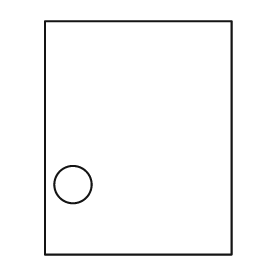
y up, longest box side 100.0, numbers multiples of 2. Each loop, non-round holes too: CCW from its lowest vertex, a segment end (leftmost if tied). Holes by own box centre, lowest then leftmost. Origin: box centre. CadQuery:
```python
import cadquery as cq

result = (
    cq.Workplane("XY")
    .moveTo(-40.0, -50.0)
    .lineTo(40.0, -50.0)
    .lineTo(40.0, 50.0)
    .lineTo(-40.0, 50.0)
    .close()
    .moveTo(-28.0, -20.0)
    .circle(8.0)
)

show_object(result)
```